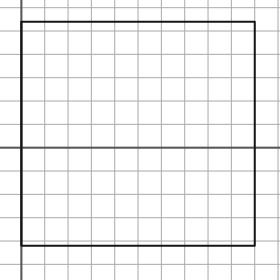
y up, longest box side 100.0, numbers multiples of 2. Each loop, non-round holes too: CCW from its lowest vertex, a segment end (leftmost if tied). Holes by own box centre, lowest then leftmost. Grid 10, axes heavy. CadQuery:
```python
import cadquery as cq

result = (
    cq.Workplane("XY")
    .moveTo(0.0, -42.0)
    .lineTo(100.0, -42.0)
    .lineTo(100.0, 54.0)
    .lineTo(0.0, 54.0)
    .close()
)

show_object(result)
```